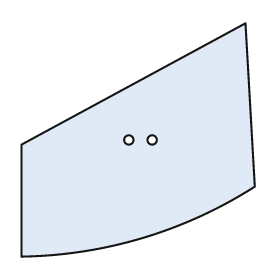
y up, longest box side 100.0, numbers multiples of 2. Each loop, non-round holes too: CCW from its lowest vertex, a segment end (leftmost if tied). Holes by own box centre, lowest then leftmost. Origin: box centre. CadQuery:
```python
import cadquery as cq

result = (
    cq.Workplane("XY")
    .moveTo(-50.0, -50.0)
    .threePointArc((2.0, -42.0), (50.0, -20.0))
    .lineTo(46.0, 50.0)
    .lineTo(-50.0, -2.0)
    .close()
    .moveTo(-4.0, 0.0)
    .circle(2.0)
    .moveTo(6.0, 0.0)
    .circle(2.0)
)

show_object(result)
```